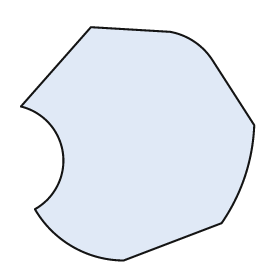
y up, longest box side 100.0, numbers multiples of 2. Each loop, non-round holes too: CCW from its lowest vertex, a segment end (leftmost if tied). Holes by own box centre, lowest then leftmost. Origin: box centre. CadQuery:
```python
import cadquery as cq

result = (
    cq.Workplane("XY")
    .moveTo(-6.0, -50.0)
    .lineTo(36.0, -34.0)
    .threePointArc((46.0, -14.0), (50.0, 8.0))
    .lineTo(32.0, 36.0)
    .threePointArc((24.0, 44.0), (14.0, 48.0))
    .lineTo(-20.0, 50.0)
    .lineTo(-50.0, 16.0)
    .threePointArc((-32.0, -4.0), (-44.0, -28.0))
    .threePointArc((-28.0, -44.0), (-6.0, -50.0))
    .close()
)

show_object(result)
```